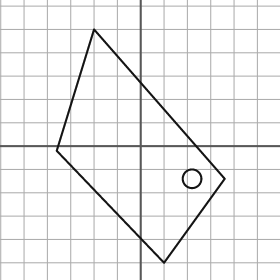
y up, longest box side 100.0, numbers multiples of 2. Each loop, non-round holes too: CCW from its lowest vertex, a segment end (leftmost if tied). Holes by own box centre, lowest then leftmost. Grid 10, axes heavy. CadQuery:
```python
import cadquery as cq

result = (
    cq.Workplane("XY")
    .moveTo(10.0, -50.0)
    .lineTo(36.0, -14.0)
    .lineTo(-20.0, 50.0)
    .lineTo(-36.0, -2.0)
    .close()
    .moveTo(22.0, -14.0)
    .circle(4.0)
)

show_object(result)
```